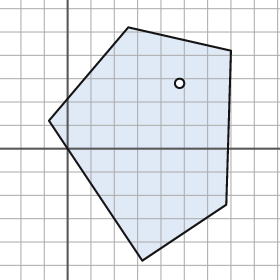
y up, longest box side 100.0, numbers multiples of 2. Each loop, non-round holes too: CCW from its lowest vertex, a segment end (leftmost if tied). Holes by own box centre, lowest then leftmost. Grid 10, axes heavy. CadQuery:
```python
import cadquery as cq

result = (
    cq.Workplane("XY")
    .moveTo(32.0, -48.0)
    .lineTo(68.0, -24.0)
    .lineTo(70.0, 42.0)
    .lineTo(26.0, 52.0)
    .lineTo(-8.0, 12.0)
    .close()
    .moveTo(48.0, 28.0)
    .circle(2.0)
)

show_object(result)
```